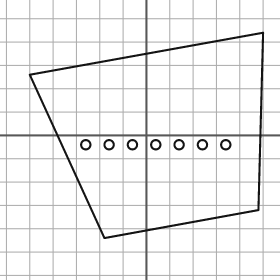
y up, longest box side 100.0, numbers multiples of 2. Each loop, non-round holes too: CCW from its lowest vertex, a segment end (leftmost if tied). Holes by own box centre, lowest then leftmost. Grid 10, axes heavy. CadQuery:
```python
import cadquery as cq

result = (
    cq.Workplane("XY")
    .moveTo(-18.0, -44.0)
    .lineTo(48.0, -32.0)
    .lineTo(50.0, 44.0)
    .lineTo(-50.0, 26.0)
    .close()
    .moveTo(-26.0, -4.0)
    .circle(2.0)
    .moveTo(-16.0, -4.0)
    .circle(2.0)
    .moveTo(-6.0, -4.0)
    .circle(2.0)
    .moveTo(4.0, -4.0)
    .circle(2.0)
    .moveTo(14.0, -4.0)
    .circle(2.0)
    .moveTo(24.0, -4.0)
    .circle(2.0)
    .moveTo(34.0, -4.0)
    .circle(2.0)
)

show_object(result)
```